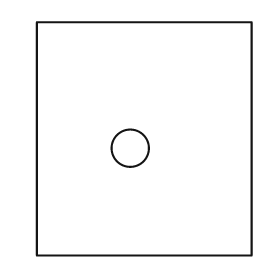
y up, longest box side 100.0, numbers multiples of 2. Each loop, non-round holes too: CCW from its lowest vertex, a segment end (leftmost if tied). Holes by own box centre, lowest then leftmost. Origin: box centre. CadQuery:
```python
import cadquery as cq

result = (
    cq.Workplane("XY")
    .moveTo(-46.0, -50.0)
    .lineTo(46.0, -50.0)
    .lineTo(46.0, 50.0)
    .lineTo(-46.0, 50.0)
    .close()
    .moveTo(-6.0, -4.0)
    .circle(8.0)
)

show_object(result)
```